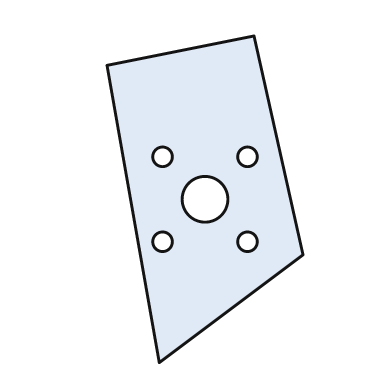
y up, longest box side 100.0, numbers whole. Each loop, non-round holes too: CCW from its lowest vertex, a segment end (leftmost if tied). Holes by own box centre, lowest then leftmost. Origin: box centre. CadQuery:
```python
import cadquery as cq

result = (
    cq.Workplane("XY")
    .moveTo(-14.0, -50.0)
    .lineTo(30.0, -17.0)
    .lineTo(15.0, 50.0)
    .lineTo(-30.0, 41.0)
    .close()
    .moveTo(-13.0, -13.0)
    .circle(3.0)
    .moveTo(13.0, -13.0)
    .circle(3.0)
    .moveTo(0.0, 0.0)
    .circle(7.0)
    .moveTo(-13.0, 13.0)
    .circle(3.0)
    .moveTo(13.0, 13.0)
    .circle(3.0)
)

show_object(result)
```